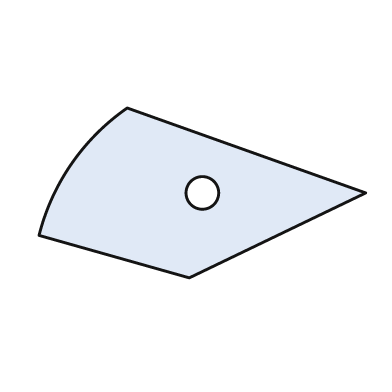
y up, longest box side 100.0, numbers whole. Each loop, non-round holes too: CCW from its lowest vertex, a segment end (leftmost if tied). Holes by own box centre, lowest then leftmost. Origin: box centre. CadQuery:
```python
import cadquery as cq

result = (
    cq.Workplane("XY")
    .moveTo(-4.0, -26.0)
    .lineTo(50.0, 0.0)
    .lineTo(-23.0, 26.0)
    .threePointArc((-40.0, 9.0), (-50.0, -13.0))
    .close()
    .moveTo(0.0, 0.0)
    .circle(5.0)
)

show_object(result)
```